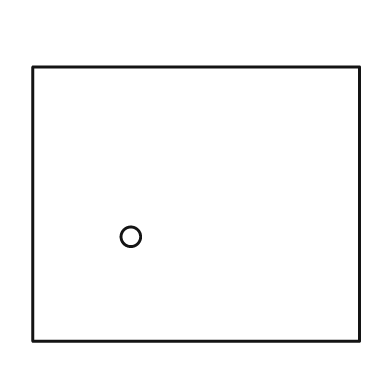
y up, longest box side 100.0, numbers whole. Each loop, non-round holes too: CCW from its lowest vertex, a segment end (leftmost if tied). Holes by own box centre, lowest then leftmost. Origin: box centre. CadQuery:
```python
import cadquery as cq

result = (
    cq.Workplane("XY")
    .moveTo(-50.0, -42.0)
    .lineTo(50.0, -42.0)
    .lineTo(50.0, 42.0)
    .lineTo(-50.0, 42.0)
    .close()
    .moveTo(-20.0, -10.0)
    .circle(3.0)
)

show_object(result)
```